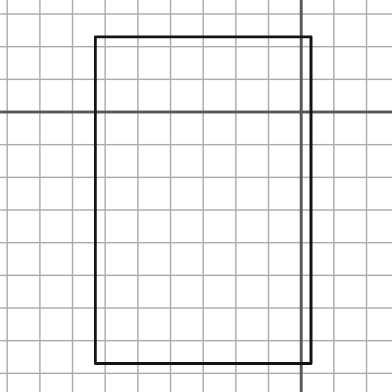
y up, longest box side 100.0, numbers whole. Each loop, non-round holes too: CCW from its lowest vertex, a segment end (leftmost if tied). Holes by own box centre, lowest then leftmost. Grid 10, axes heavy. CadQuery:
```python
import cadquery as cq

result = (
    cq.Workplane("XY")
    .moveTo(-63.0, -77.0)
    .lineTo(3.0, -77.0)
    .lineTo(3.0, 23.0)
    .lineTo(-63.0, 23.0)
    .close()
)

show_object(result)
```